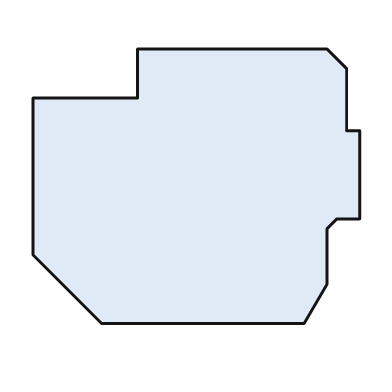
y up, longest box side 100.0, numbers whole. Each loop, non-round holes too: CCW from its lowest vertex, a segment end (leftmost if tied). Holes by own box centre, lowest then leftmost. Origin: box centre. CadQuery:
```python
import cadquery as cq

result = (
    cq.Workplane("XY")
    .moveTo(-29.0, -42.0)
    .lineTo(33.0, -42.0)
    .lineTo(40.0, -30.0)
    .lineTo(40.0, -13.0)
    .lineTo(43.0, -10.0)
    .lineTo(50.0, -10.0)
    .lineTo(50.0, 17.0)
    .lineTo(46.0, 17.0)
    .lineTo(46.0, 36.0)
    .lineTo(40.0, 42.0)
    .lineTo(-18.0, 42.0)
    .lineTo(-18.0, 27.0)
    .lineTo(-50.0, 27.0)
    .lineTo(-50.0, -21.0)
    .close()
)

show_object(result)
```